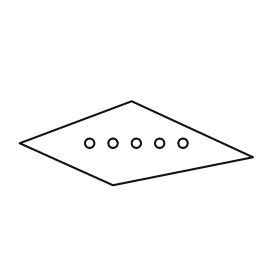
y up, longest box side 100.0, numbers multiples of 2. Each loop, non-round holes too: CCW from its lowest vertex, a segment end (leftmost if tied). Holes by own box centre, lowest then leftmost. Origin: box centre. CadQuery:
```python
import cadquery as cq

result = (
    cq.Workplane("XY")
    .moveTo(-10.0, -18.0)
    .lineTo(50.0, -6.0)
    .lineTo(-2.0, 18.0)
    .lineTo(-50.0, 0.0)
    .close()
    .moveTo(-20.0, 0.0)
    .circle(2.0)
    .moveTo(-10.0, 0.0)
    .circle(2.0)
    .moveTo(0.0, 0.0)
    .circle(2.0)
    .moveTo(10.0, 0.0)
    .circle(2.0)
    .moveTo(20.0, 0.0)
    .circle(2.0)
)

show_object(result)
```